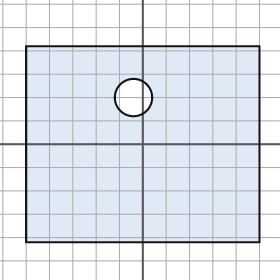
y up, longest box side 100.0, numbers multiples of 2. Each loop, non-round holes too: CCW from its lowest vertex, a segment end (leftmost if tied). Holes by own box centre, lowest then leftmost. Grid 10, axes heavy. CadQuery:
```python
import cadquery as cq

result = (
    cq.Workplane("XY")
    .moveTo(-50.0, -42.0)
    .lineTo(50.0, -42.0)
    .lineTo(50.0, 42.0)
    .lineTo(-50.0, 42.0)
    .close()
    .moveTo(-4.0, 20.0)
    .circle(8.0)
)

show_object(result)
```